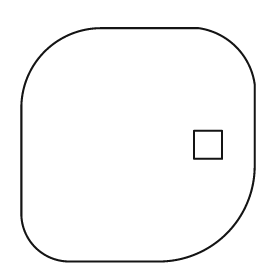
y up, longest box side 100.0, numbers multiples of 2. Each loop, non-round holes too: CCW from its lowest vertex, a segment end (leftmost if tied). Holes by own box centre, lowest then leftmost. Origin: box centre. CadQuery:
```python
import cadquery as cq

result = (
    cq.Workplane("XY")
    .moveTo(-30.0, -50.0)
    .lineTo(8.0, -50.0)
    .threePointArc((38.0, -38.0), (50.0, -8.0))
    .lineTo(50.0, 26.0)
    .threePointArc((42.0, 42.0), (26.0, 50.0))
    .lineTo(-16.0, 50.0)
    .threePointArc((-40.0, 40.0), (-50.0, 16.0))
    .lineTo(-50.0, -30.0)
    .threePointArc((-44.0, -44.0), (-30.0, -50.0))
    .close()
    .moveTo(24.0, -6.0)
    .lineTo(36.0, -6.0)
    .lineTo(36.0, 6.0)
    .lineTo(24.0, 6.0)
    .close()
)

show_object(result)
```